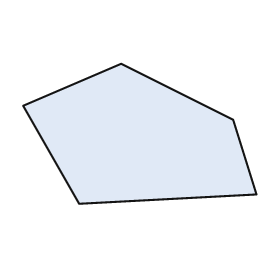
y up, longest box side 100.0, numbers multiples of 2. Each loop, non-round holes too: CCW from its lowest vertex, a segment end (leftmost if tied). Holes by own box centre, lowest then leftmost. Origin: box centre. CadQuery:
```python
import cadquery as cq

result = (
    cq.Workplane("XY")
    .moveTo(-26.0, -30.0)
    .lineTo(50.0, -26.0)
    .lineTo(40.0, 6.0)
    .lineTo(-8.0, 30.0)
    .lineTo(-50.0, 12.0)
    .close()
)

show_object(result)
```